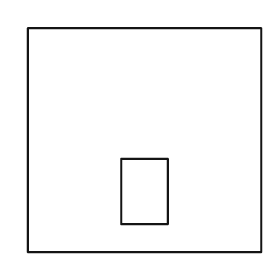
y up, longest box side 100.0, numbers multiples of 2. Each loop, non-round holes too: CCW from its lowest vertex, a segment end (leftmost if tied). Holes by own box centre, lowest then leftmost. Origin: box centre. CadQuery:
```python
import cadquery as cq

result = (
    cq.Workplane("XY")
    .moveTo(-50.0, -48.0)
    .lineTo(50.0, -48.0)
    .lineTo(50.0, 48.0)
    .lineTo(-50.0, 48.0)
    .close()
    .moveTo(-10.0, -36.0)
    .lineTo(10.0, -36.0)
    .lineTo(10.0, -8.0)
    .lineTo(-10.0, -8.0)
    .close()
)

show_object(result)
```